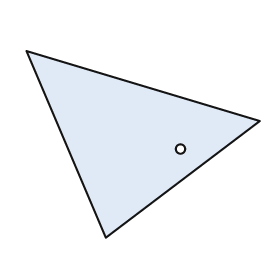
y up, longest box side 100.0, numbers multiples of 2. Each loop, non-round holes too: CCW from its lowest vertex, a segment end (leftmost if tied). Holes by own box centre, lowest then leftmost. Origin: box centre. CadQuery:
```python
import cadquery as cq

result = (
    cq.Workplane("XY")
    .moveTo(-16.0, -40.0)
    .lineTo(50.0, 10.0)
    .lineTo(-50.0, 40.0)
    .close()
    .moveTo(16.0, -2.0)
    .circle(2.0)
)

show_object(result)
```